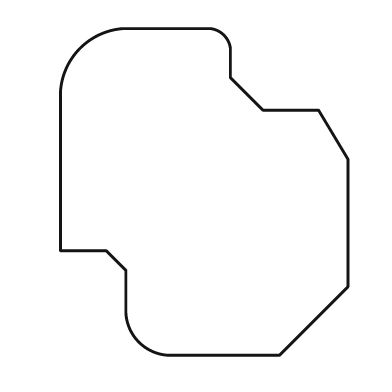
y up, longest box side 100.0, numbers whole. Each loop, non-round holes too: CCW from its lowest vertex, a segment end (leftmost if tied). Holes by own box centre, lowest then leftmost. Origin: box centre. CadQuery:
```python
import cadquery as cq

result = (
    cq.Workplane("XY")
    .moveTo(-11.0, -50.0)
    .lineTo(23.0, -50.0)
    .lineTo(44.0, -29.0)
    .lineTo(44.0, 10.0)
    .lineTo(35.0, 25.0)
    .lineTo(18.0, 25.0)
    .lineTo(8.0, 35.0)
    .lineTo(8.0, 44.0)
    .threePointArc((6.0, 48.0), (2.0, 50.0))
    .lineTo(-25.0, 50.0)
    .threePointArc((-38.0, 44.0), (-44.0, 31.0))
    .lineTo(-44.0, -18.0)
    .lineTo(-30.0, -18.0)
    .lineTo(-24.0, -24.0)
    .lineTo(-24.0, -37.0)
    .threePointArc((-20.0, -46.0), (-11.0, -50.0))
    .close()
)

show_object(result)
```